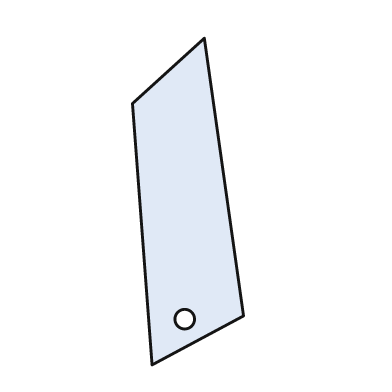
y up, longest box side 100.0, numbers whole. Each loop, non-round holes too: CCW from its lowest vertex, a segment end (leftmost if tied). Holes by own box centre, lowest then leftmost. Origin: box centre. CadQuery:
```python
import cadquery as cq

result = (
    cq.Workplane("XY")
    .moveTo(-11.0, -50.0)
    .lineTo(17.0, -35.0)
    .lineTo(5.0, 50.0)
    .lineTo(-17.0, 30.0)
    .close()
    .moveTo(-1.0, -36.0)
    .circle(3.0)
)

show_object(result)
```